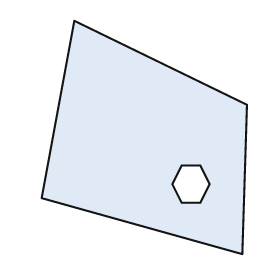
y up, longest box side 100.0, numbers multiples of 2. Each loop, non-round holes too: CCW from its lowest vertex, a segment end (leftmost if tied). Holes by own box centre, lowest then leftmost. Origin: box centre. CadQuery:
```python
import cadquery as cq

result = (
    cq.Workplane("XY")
    .moveTo(42.0, -50.0)
    .lineTo(44.0, 14.0)
    .lineTo(-30.0, 50.0)
    .lineTo(-44.0, -26.0)
    .close()
    .moveTo(16.0, -28.0)
    .lineTo(24.0, -28.0)
    .lineTo(28.0, -20.0)
    .lineTo(24.0, -12.0)
    .lineTo(16.0, -12.0)
    .lineTo(12.0, -20.0)
    .close()
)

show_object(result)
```